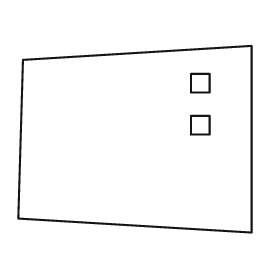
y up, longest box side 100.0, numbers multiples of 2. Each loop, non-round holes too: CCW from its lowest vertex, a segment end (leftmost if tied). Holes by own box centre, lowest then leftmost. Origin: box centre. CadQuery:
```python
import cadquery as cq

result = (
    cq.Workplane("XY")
    .moveTo(50.0, -40.0)
    .lineTo(50.0, 40.0)
    .lineTo(-48.0, 34.0)
    .lineTo(-50.0, -34.0)
    .close()
    .moveTo(24.0, 2.0)
    .lineTo(32.0, 2.0)
    .lineTo(32.0, 10.0)
    .lineTo(24.0, 10.0)
    .close()
    .moveTo(24.0, 20.0)
    .lineTo(32.0, 20.0)
    .lineTo(32.0, 28.0)
    .lineTo(24.0, 28.0)
    .close()
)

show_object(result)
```